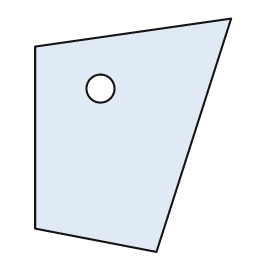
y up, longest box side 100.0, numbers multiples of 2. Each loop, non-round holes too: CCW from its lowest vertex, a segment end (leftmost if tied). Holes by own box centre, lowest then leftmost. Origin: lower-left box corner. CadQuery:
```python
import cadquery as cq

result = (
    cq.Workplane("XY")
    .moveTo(52.0, 0.0)
    .lineTo(84.0, 100.0)
    .lineTo(0.0, 88.0)
    .lineTo(0.0, 10.0)
    .close()
    .moveTo(28.0, 70.0)
    .circle(6.0)
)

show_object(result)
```